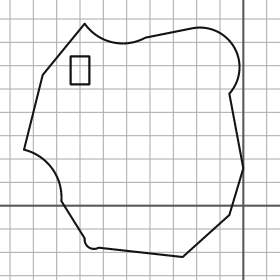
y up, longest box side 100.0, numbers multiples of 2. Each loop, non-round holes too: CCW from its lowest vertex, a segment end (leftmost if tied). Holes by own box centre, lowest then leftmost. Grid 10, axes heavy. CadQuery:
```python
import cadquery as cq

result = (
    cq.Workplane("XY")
    .moveTo(-26.0, -22.0)
    .lineTo(-6.0, -4.0)
    .lineTo(0.0, 16.0)
    .lineTo(-6.0, 48.0)
    .threePointArc((-4.0, 68.0), (-22.0, 76.0))
    .lineTo(-42.0, 72.0)
    .threePointArc((-56.0, 70.0), (-68.0, 78.0))
    .lineTo(-86.0, 56.0)
    .lineTo(-94.0, 24.0)
    .threePointArc((-82.0, 16.0), (-78.0, 2.0))
    .lineTo(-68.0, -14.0)
    .threePointArc((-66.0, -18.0), (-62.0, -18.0))
    .close()
    .moveTo(-74.0, 52.0)
    .lineTo(-66.0, 52.0)
    .lineTo(-66.0, 64.0)
    .lineTo(-74.0, 64.0)
    .close()
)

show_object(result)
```